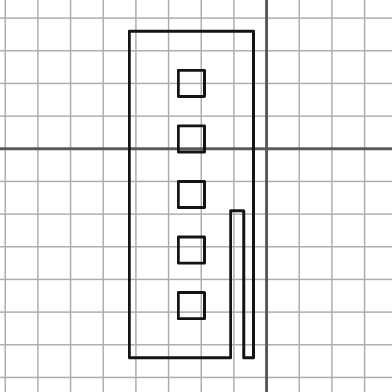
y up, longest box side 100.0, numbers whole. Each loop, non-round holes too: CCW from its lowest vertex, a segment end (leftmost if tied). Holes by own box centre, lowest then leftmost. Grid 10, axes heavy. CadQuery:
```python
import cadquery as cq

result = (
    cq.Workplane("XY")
    .moveTo(-42.0, -64.0)
    .lineTo(-11.0, -64.0)
    .lineTo(-11.0, -19.0)
    .lineTo(-7.0, -19.0)
    .lineTo(-7.0, -64.0)
    .lineTo(-4.0, -64.0)
    .lineTo(-4.0, 36.0)
    .lineTo(-42.0, 36.0)
    .close()
    .moveTo(-27.0, -52.0)
    .lineTo(-19.0, -52.0)
    .lineTo(-19.0, -44.0)
    .lineTo(-27.0, -44.0)
    .close()
    .moveTo(-27.0, -35.0)
    .lineTo(-19.0, -35.0)
    .lineTo(-19.0, -27.0)
    .lineTo(-27.0, -27.0)
    .close()
    .moveTo(-27.0, -18.0)
    .lineTo(-19.0, -18.0)
    .lineTo(-19.0, -10.0)
    .lineTo(-27.0, -10.0)
    .close()
    .moveTo(-27.0, -1.0)
    .lineTo(-19.0, -1.0)
    .lineTo(-19.0, 7.0)
    .lineTo(-27.0, 7.0)
    .close()
    .moveTo(-27.0, 16.0)
    .lineTo(-19.0, 16.0)
    .lineTo(-19.0, 24.0)
    .lineTo(-27.0, 24.0)
    .close()
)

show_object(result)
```